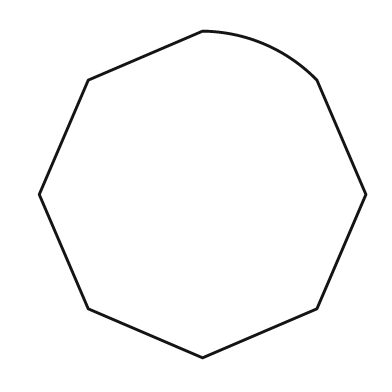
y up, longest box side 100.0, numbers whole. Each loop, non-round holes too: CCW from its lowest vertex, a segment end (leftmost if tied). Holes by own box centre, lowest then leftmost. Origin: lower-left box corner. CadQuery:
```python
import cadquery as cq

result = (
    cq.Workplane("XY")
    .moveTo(50.0, 0.0)
    .lineTo(85.0, 15.0)
    .lineTo(100.0, 50.0)
    .lineTo(85.0, 85.0)
    .threePointArc((69.0, 96.0), (50.0, 100.0))
    .lineTo(15.0, 85.0)
    .lineTo(0.0, 50.0)
    .lineTo(15.0, 15.0)
    .close()
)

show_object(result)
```